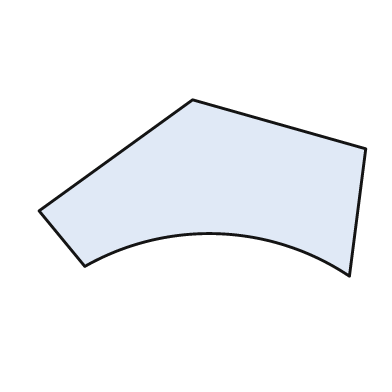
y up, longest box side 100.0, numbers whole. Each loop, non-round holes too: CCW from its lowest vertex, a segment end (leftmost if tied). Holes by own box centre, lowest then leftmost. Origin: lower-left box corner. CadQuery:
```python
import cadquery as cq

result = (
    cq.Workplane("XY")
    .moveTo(95.0, 0.0)
    .lineTo(100.0, 39.0)
    .lineTo(47.0, 54.0)
    .lineTo(0.0, 20.0)
    .lineTo(14.0, 3.0)
    .threePointArc((55.0, 13.0), (95.0, 0.0))
    .close()
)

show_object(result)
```